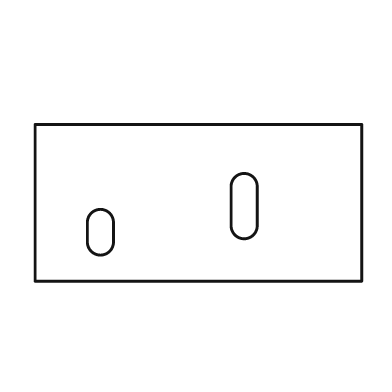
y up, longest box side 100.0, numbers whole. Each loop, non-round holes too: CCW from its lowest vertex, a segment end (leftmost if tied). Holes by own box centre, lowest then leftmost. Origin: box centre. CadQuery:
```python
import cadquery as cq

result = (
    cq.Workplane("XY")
    .moveTo(-50.0, -24.0)
    .lineTo(50.0, -24.0)
    .lineTo(50.0, 24.0)
    .lineTo(-50.0, 24.0)
    .close()
    .moveTo(-34.0, -12.0)
    .threePointArc((-30.0, -16.0), (-26.0, -12.0))
    .lineTo(-26.0, -6.0)
    .threePointArc((-30.0, -2.0), (-34.0, -6.0))
    .close()
    .moveTo(10.0, -7.0)
    .threePointArc((14.0, -11.0), (18.0, -7.0))
    .lineTo(18.0, 5.0)
    .threePointArc((14.0, 9.0), (10.0, 5.0))
    .close()
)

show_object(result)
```